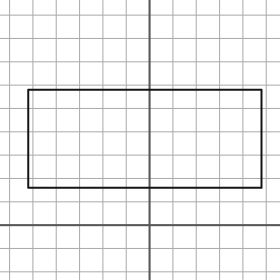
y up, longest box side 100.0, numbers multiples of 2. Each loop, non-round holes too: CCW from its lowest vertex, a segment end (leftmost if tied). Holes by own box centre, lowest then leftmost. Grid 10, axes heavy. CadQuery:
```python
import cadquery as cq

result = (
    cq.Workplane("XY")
    .moveTo(-52.0, 16.0)
    .lineTo(48.0, 16.0)
    .lineTo(48.0, 58.0)
    .lineTo(-52.0, 58.0)
    .close()
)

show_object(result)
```